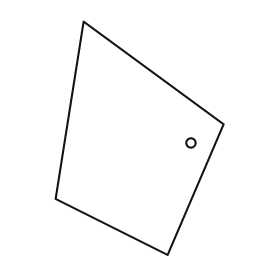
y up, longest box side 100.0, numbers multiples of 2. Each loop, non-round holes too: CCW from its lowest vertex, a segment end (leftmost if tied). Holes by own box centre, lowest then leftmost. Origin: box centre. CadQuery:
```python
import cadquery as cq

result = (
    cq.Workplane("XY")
    .moveTo(12.0, -50.0)
    .lineTo(36.0, 6.0)
    .lineTo(-24.0, 50.0)
    .lineTo(-36.0, -26.0)
    .close()
    .moveTo(22.0, -2.0)
    .circle(2.0)
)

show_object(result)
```